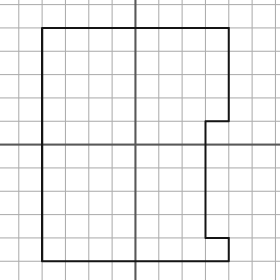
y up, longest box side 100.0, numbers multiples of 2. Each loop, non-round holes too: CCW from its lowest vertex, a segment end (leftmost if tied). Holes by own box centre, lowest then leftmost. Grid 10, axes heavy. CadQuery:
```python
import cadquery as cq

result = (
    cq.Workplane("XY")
    .moveTo(-40.0, -50.0)
    .lineTo(40.0, -50.0)
    .lineTo(40.0, -40.0)
    .lineTo(30.0, -40.0)
    .lineTo(30.0, 10.0)
    .lineTo(40.0, 10.0)
    .lineTo(40.0, 50.0)
    .lineTo(-40.0, 50.0)
    .close()
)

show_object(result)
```